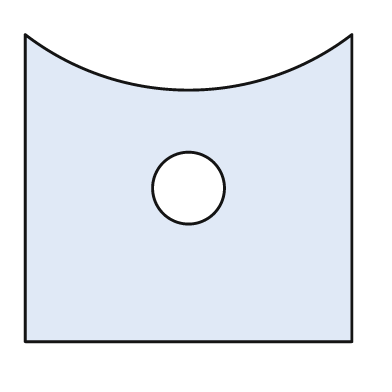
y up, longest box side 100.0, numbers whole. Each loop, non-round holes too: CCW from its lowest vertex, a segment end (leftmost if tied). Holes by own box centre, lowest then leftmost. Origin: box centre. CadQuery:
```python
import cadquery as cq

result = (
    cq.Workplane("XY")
    .moveTo(-50.0, -47.0)
    .lineTo(50.0, -47.0)
    .lineTo(50.0, 47.0)
    .threePointArc((0.0, 30.0), (-50.0, 47.0))
    .close()
    .moveTo(0.0, 0.0)
    .circle(11.0)
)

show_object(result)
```